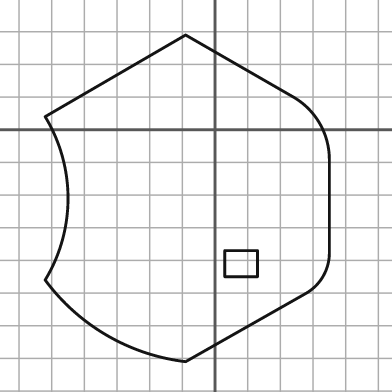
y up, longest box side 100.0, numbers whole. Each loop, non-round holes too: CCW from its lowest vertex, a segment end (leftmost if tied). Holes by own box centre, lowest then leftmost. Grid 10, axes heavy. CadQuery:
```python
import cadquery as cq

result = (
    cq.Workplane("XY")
    .moveTo(-9.0, -71.0)
    .lineTo(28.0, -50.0)
    .threePointArc((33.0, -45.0), (35.0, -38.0))
    .lineTo(35.0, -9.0)
    .threePointArc((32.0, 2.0), (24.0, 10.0))
    .lineTo(-9.0, 29.0)
    .lineTo(-52.0, 4.0)
    .threePointArc((-45.0, -21.0), (-52.0, -46.0))
    .threePointArc((-33.0, -63.0), (-9.0, -71.0))
    .close()
    .moveTo(3.0, -45.0)
    .lineTo(13.0, -45.0)
    .lineTo(13.0, -37.0)
    .lineTo(3.0, -37.0)
    .close()
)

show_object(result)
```